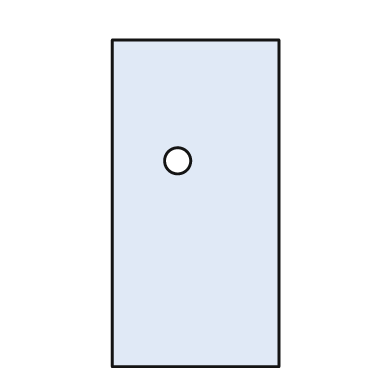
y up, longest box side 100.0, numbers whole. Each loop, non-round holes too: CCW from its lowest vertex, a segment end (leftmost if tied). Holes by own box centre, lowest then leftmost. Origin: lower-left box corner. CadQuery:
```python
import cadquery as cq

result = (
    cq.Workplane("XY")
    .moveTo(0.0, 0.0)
    .lineTo(51.0, 0.0)
    .lineTo(51.0, 100.0)
    .lineTo(0.0, 100.0)
    .close()
    .moveTo(20.0, 63.0)
    .circle(4.0)
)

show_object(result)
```